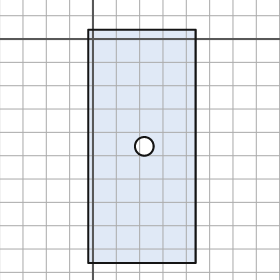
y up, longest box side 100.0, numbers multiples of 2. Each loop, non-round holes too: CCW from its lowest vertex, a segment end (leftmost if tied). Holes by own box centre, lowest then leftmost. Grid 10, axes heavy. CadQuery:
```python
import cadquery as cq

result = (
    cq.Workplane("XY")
    .moveTo(-2.0, -96.0)
    .lineTo(44.0, -96.0)
    .lineTo(44.0, 4.0)
    .lineTo(-2.0, 4.0)
    .close()
    .moveTo(22.0, -46.0)
    .circle(4.0)
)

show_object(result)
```